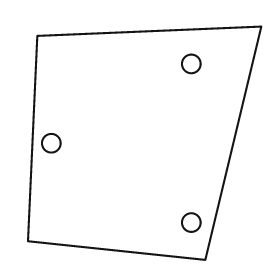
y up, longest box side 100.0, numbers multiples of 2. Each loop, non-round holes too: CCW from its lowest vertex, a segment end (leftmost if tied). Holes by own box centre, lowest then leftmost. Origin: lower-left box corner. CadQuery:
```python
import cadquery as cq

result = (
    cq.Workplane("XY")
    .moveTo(76.0, 0.0)
    .lineTo(100.0, 100.0)
    .lineTo(4.0, 96.0)
    .lineTo(0.0, 8.0)
    .close()
    .moveTo(70.0, 16.0)
    .circle(4.0)
    .moveTo(10.0, 50.0)
    .circle(4.0)
    .moveTo(70.0, 84.0)
    .circle(4.0)
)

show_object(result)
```